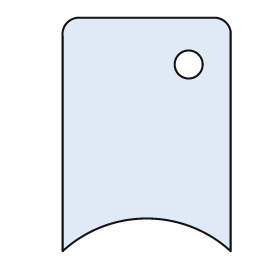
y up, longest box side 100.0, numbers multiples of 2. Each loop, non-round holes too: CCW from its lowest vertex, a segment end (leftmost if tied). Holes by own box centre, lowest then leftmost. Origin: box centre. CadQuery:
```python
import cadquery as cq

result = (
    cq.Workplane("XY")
    .moveTo(-36.0, -50.0)
    .threePointArc((0.0, -36.0), (36.0, -50.0))
    .lineTo(36.0, 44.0)
    .threePointArc((34.0, 48.0), (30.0, 50.0))
    .lineTo(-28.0, 50.0)
    .threePointArc((-34.0, 48.0), (-36.0, 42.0))
    .close()
    .moveTo(18.0, 30.0)
    .circle(6.0)
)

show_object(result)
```